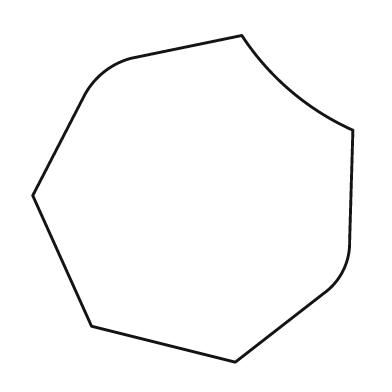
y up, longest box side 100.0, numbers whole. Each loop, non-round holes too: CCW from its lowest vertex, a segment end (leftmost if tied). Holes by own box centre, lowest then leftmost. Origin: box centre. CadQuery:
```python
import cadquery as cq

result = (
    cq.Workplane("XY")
    .moveTo(13.0, -50.0)
    .lineTo(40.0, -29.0)
    .threePointArc((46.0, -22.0), (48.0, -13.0))
    .lineTo(49.0, 21.0)
    .threePointArc((30.0, 33.0), (15.0, 50.0))
    .lineTo(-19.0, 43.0)
    .threePointArc((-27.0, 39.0), (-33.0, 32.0))
    .lineTo(-49.0, 1.0)
    .lineTo(-31.0, -39.0)
    .close()
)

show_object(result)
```